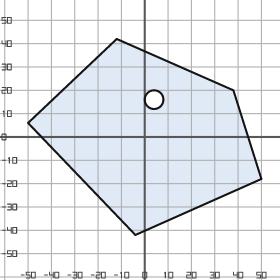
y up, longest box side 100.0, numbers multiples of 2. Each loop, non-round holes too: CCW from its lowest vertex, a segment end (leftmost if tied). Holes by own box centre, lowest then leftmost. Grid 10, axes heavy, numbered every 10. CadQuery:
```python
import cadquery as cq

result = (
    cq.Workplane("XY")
    .moveTo(-4.0, -42.0)
    .lineTo(50.0, -18.0)
    .lineTo(38.0, 20.0)
    .lineTo(-12.0, 42.0)
    .lineTo(-50.0, 6.0)
    .close()
    .moveTo(4.0, 16.0)
    .circle(4.0)
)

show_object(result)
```